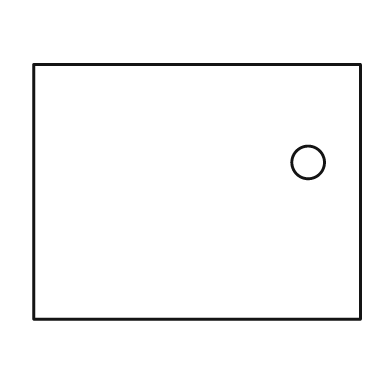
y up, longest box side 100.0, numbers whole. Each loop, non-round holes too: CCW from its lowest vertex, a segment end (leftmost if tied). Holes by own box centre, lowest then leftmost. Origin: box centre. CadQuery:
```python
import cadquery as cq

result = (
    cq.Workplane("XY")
    .moveTo(-50.0, -39.0)
    .lineTo(50.0, -39.0)
    .lineTo(50.0, 39.0)
    .lineTo(-50.0, 39.0)
    .close()
    .moveTo(34.0, 9.0)
    .circle(5.0)
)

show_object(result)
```